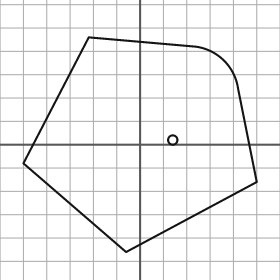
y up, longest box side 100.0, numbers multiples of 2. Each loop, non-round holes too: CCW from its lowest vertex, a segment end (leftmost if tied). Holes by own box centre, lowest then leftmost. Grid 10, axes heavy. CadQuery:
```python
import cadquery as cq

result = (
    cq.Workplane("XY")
    .moveTo(-6.0, -46.0)
    .lineTo(50.0, -16.0)
    .lineTo(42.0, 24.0)
    .threePointArc((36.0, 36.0), (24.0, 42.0))
    .lineTo(-22.0, 46.0)
    .lineTo(-50.0, -8.0)
    .close()
    .moveTo(14.0, 2.0)
    .circle(2.0)
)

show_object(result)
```